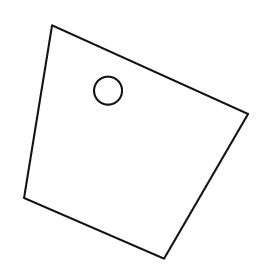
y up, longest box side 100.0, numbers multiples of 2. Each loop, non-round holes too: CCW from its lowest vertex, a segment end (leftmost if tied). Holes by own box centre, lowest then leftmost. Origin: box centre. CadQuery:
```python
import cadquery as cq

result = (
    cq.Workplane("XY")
    .moveTo(12.0, -50.0)
    .lineTo(48.0, 12.0)
    .lineTo(-36.0, 50.0)
    .lineTo(-48.0, -24.0)
    .close()
    .moveTo(-12.0, 22.0)
    .circle(6.0)
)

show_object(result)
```